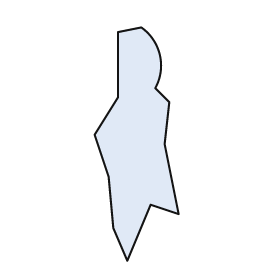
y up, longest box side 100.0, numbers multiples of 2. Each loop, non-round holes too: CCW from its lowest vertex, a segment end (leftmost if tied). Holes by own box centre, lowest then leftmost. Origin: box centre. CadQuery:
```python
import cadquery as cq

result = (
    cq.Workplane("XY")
    .moveTo(-4.0, -50.0)
    .lineTo(6.0, -26.0)
    .lineTo(18.0, -30.0)
    .lineTo(12.0, 0.0)
    .lineTo(14.0, 18.0)
    .lineTo(8.0, 24.0)
    .threePointArc((10.0, 38.0), (2.0, 50.0))
    .lineTo(-8.0, 48.0)
    .lineTo(-8.0, 20.0)
    .lineTo(-18.0, 4.0)
    .lineTo(-12.0, -14.0)
    .lineTo(-10.0, -36.0)
    .close()
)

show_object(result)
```